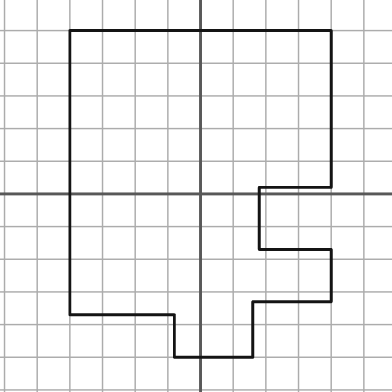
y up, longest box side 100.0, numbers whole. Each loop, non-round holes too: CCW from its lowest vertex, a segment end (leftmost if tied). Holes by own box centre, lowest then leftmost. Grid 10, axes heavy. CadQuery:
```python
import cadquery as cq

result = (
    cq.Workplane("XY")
    .moveTo(-8.0, -50.0)
    .lineTo(16.0, -50.0)
    .lineTo(16.0, -33.0)
    .lineTo(40.0, -33.0)
    .lineTo(40.0, -17.0)
    .lineTo(18.0, -17.0)
    .lineTo(18.0, 2.0)
    .lineTo(40.0, 2.0)
    .lineTo(40.0, 50.0)
    .lineTo(-40.0, 50.0)
    .lineTo(-40.0, -37.0)
    .lineTo(-8.0, -37.0)
    .close()
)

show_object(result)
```